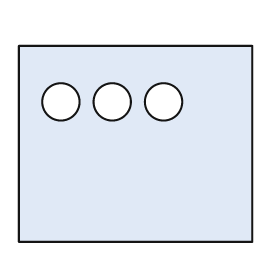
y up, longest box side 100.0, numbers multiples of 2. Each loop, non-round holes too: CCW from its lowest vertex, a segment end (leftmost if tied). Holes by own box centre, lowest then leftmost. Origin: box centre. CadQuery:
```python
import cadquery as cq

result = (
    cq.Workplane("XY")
    .moveTo(-50.0, -42.0)
    .lineTo(50.0, -42.0)
    .lineTo(50.0, 42.0)
    .lineTo(-50.0, 42.0)
    .close()
    .moveTo(-32.0, 18.0)
    .circle(8.0)
    .moveTo(-10.0, 18.0)
    .circle(8.0)
    .moveTo(12.0, 18.0)
    .circle(8.0)
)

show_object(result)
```